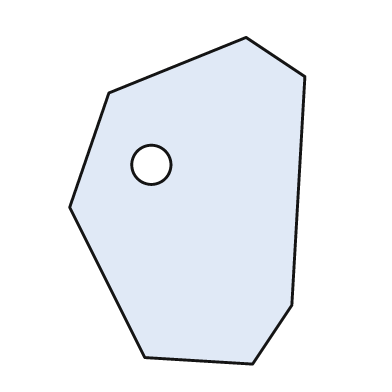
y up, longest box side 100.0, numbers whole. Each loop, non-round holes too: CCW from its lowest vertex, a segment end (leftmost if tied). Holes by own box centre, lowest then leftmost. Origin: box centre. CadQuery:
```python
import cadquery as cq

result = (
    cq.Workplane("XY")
    .moveTo(20.0, -50.0)
    .lineTo(32.0, -32.0)
    .lineTo(36.0, 38.0)
    .lineTo(18.0, 50.0)
    .lineTo(-24.0, 33.0)
    .lineTo(-36.0, -2.0)
    .lineTo(-13.0, -48.0)
    .close()
    .moveTo(-11.0, 11.0)
    .circle(6.0)
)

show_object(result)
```